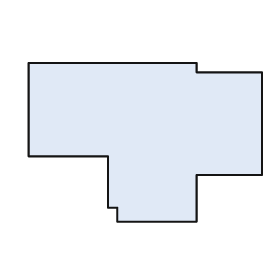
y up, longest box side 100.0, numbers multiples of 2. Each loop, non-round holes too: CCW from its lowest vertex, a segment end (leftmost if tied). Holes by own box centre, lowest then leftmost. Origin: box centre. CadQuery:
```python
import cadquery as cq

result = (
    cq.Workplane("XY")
    .moveTo(-12.0, -34.0)
    .lineTo(22.0, -34.0)
    .lineTo(22.0, -14.0)
    .lineTo(50.0, -14.0)
    .lineTo(50.0, 30.0)
    .lineTo(22.0, 30.0)
    .lineTo(22.0, 34.0)
    .lineTo(-50.0, 34.0)
    .lineTo(-50.0, -6.0)
    .lineTo(-16.0, -6.0)
    .lineTo(-16.0, -28.0)
    .lineTo(-12.0, -28.0)
    .close()
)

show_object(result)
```